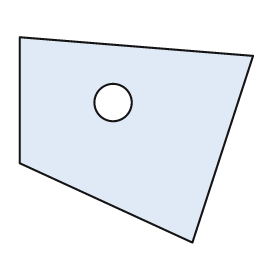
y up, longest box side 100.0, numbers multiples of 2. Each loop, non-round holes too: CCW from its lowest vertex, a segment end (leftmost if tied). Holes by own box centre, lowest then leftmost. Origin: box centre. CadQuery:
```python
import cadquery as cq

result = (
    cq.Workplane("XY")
    .moveTo(24.0, -44.0)
    .lineTo(50.0, 36.0)
    .lineTo(-50.0, 44.0)
    .lineTo(-50.0, -10.0)
    .close()
    .moveTo(-10.0, 16.0)
    .circle(8.0)
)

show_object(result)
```